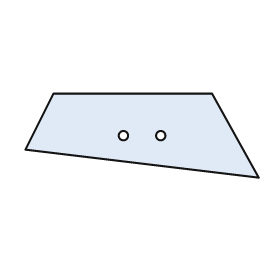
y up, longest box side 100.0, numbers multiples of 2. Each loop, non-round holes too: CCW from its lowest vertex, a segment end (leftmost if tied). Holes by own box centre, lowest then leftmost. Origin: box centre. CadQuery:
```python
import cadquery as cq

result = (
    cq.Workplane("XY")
    .moveTo(50.0, -18.0)
    .lineTo(30.0, 18.0)
    .lineTo(-38.0, 18.0)
    .lineTo(-50.0, -6.0)
    .close()
    .moveTo(-8.0, 0.0)
    .circle(2.0)
    .moveTo(8.0, 0.0)
    .circle(2.0)
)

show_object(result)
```